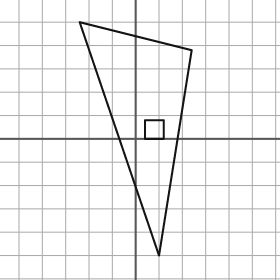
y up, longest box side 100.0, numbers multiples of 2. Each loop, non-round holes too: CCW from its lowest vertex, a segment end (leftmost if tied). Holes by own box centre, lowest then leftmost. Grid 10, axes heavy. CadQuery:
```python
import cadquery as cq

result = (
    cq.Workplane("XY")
    .moveTo(10.0, -50.0)
    .lineTo(24.0, 38.0)
    .lineTo(-24.0, 50.0)
    .close()
    .moveTo(4.0, 0.0)
    .lineTo(12.0, 0.0)
    .lineTo(12.0, 8.0)
    .lineTo(4.0, 8.0)
    .close()
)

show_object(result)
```